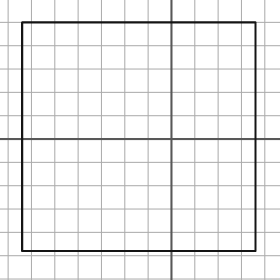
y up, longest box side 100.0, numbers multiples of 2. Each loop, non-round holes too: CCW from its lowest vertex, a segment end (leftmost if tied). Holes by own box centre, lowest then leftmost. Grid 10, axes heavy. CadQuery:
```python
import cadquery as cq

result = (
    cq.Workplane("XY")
    .moveTo(-64.0, -48.0)
    .lineTo(36.0, -48.0)
    .lineTo(36.0, 50.0)
    .lineTo(-64.0, 50.0)
    .close()
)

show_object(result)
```